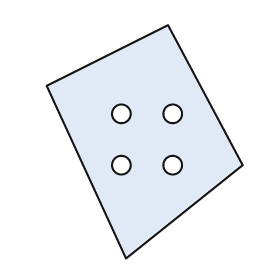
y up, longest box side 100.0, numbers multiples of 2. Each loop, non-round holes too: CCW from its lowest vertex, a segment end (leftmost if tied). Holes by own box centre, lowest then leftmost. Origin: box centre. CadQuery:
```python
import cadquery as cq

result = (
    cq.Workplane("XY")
    .moveTo(-8.0, -50.0)
    .lineTo(42.0, -10.0)
    .lineTo(10.0, 50.0)
    .lineTo(-42.0, 24.0)
    .close()
    .moveTo(-10.0, -10.0)
    .circle(4.0)
    .moveTo(12.0, -10.0)
    .circle(4.0)
    .moveTo(-10.0, 12.0)
    .circle(4.0)
    .moveTo(12.0, 12.0)
    .circle(4.0)
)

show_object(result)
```